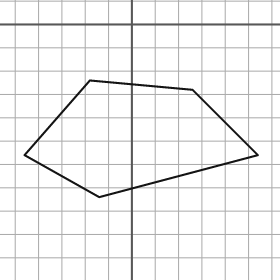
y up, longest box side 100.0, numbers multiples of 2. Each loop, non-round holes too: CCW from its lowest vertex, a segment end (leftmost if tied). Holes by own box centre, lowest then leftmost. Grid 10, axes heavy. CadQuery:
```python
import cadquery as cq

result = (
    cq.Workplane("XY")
    .moveTo(-14.0, -74.0)
    .lineTo(54.0, -56.0)
    .lineTo(26.0, -28.0)
    .lineTo(-18.0, -24.0)
    .lineTo(-46.0, -56.0)
    .close()
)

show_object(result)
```